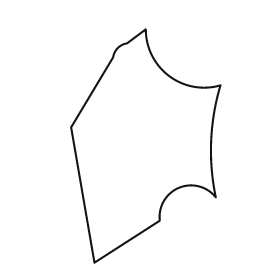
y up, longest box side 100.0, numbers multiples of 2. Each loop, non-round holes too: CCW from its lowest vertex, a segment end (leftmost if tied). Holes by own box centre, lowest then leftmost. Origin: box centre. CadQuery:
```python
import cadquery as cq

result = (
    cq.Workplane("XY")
    .moveTo(-22.0, -50.0)
    .lineTo(6.0, -32.0)
    .threePointArc((14.0, -18.0), (30.0, -22.0))
    .threePointArc((28.0, 2.0), (32.0, 26.0))
    .threePointArc((10.0, 30.0), (0.0, 50.0))
    .lineTo(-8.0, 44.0)
    .threePointArc((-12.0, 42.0), (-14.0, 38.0))
    .lineTo(-32.0, 8.0)
    .close()
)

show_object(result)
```